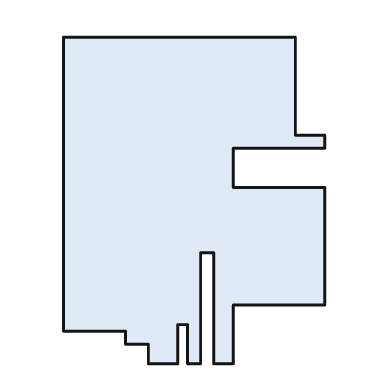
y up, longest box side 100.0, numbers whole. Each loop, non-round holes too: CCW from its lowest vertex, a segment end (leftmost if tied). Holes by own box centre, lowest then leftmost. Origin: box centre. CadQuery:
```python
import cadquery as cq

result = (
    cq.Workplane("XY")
    .moveTo(-14.0, -50.0)
    .lineTo(-5.0, -50.0)
    .lineTo(-5.0, -38.0)
    .lineTo(-2.0, -38.0)
    .lineTo(-2.0, -50.0)
    .lineTo(2.0, -50.0)
    .lineTo(2.0, -16.0)
    .lineTo(6.0, -16.0)
    .lineTo(6.0, -50.0)
    .lineTo(12.0, -50.0)
    .lineTo(12.0, -32.0)
    .lineTo(40.0, -32.0)
    .lineTo(40.0, 4.0)
    .lineTo(12.0, 4.0)
    .lineTo(12.0, 16.0)
    .lineTo(40.0, 16.0)
    .lineTo(40.0, 20.0)
    .lineTo(31.0, 20.0)
    .lineTo(31.0, 50.0)
    .lineTo(-40.0, 50.0)
    .lineTo(-40.0, -40.0)
    .lineTo(-21.0, -40.0)
    .lineTo(-21.0, -44.0)
    .lineTo(-14.0, -44.0)
    .close()
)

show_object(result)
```